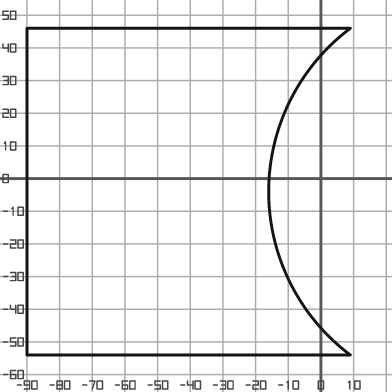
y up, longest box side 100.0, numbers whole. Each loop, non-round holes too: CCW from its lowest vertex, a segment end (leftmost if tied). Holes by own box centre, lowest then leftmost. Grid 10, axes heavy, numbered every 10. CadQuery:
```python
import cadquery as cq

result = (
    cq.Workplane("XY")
    .moveTo(-90.0, -54.0)
    .lineTo(9.0, -54.0)
    .threePointArc((-16.0, -4.0), (9.0, 46.0))
    .lineTo(-90.0, 46.0)
    .close()
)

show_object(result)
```